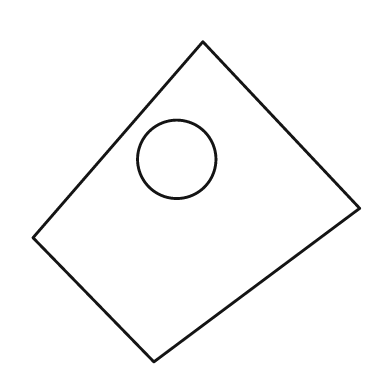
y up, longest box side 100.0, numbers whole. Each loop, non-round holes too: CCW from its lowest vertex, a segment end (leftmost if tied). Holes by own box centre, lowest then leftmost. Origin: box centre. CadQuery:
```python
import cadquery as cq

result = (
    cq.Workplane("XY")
    .moveTo(-13.0, -49.0)
    .lineTo(50.0, -2.0)
    .lineTo(2.0, 49.0)
    .lineTo(-50.0, -11.0)
    .close()
    .moveTo(-6.0, 13.0)
    .circle(12.0)
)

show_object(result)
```